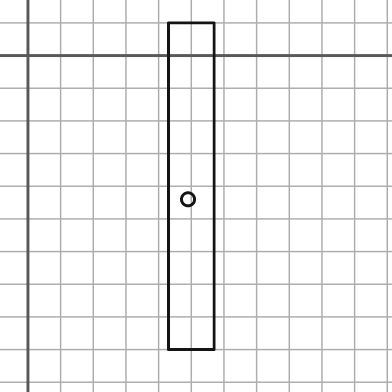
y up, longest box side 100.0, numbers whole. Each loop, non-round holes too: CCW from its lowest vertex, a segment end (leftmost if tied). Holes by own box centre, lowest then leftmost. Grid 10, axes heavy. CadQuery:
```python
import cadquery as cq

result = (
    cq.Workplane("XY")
    .moveTo(43.0, -90.0)
    .lineTo(57.0, -90.0)
    .lineTo(57.0, 10.0)
    .lineTo(43.0, 10.0)
    .close()
    .moveTo(49.0, -44.0)
    .circle(2.0)
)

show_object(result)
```